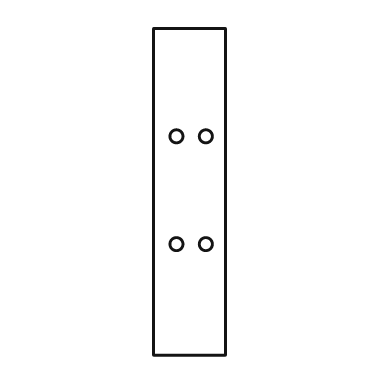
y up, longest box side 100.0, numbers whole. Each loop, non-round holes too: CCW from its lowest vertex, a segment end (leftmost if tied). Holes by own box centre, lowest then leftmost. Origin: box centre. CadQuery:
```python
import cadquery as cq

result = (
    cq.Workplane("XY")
    .moveTo(-11.0, -50.0)
    .lineTo(11.0, -50.0)
    .lineTo(11.0, 50.0)
    .lineTo(-11.0, 50.0)
    .close()
    .moveTo(-4.0, -16.0)
    .circle(2.0)
    .moveTo(5.0, -16.0)
    .circle(2.0)
    .moveTo(-4.0, 17.0)
    .circle(2.0)
    .moveTo(5.0, 17.0)
    .circle(2.0)
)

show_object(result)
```